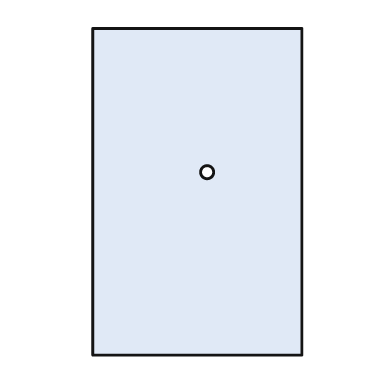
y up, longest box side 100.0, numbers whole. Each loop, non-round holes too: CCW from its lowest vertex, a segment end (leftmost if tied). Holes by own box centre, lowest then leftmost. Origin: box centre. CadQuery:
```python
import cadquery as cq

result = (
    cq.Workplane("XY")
    .moveTo(-32.0, -50.0)
    .lineTo(32.0, -50.0)
    .lineTo(32.0, 50.0)
    .lineTo(-32.0, 50.0)
    .close()
    .moveTo(3.0, 6.0)
    .circle(2.0)
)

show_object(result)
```